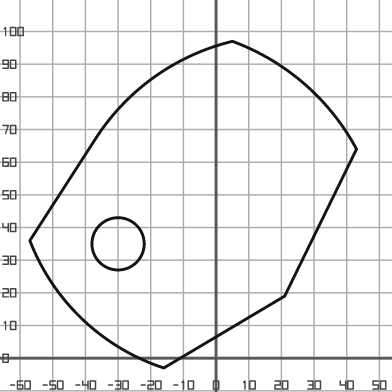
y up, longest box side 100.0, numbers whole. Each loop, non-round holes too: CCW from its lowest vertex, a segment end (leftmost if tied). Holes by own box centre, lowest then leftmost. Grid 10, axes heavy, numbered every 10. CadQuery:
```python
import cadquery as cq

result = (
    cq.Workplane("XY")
    .moveTo(-16.0, -3.0)
    .lineTo(21.0, 19.0)
    .lineTo(43.0, 64.0)
    .threePointArc((27.0, 84.0), (5.0, 97.0))
    .threePointArc((-19.0, 86.0), (-37.0, 67.0))
    .lineTo(-57.0, 36.0)
    .threePointArc((-41.0, 12.0), (-16.0, -3.0))
    .close()
    .moveTo(-30.0, 35.0)
    .circle(8.0)
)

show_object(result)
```